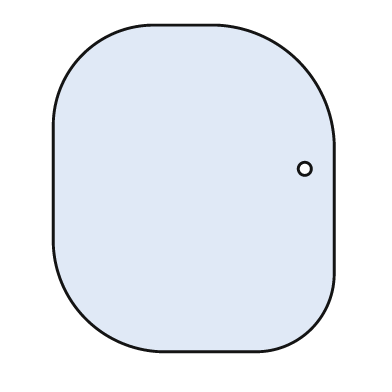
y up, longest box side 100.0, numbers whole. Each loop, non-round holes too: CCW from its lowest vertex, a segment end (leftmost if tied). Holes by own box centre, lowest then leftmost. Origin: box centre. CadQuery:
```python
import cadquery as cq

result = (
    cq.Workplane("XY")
    .moveTo(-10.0, -50.0)
    .lineTo(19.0, -50.0)
    .threePointArc((36.0, -43.0), (43.0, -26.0))
    .lineTo(43.0, 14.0)
    .threePointArc((32.0, 39.0), (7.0, 50.0))
    .lineTo(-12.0, 50.0)
    .threePointArc((-34.0, 41.0), (-43.0, 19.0))
    .lineTo(-43.0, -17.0)
    .threePointArc((-33.0, -40.0), (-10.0, -50.0))
    .close()
    .moveTo(34.0, 6.0)
    .circle(2.0)
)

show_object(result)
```